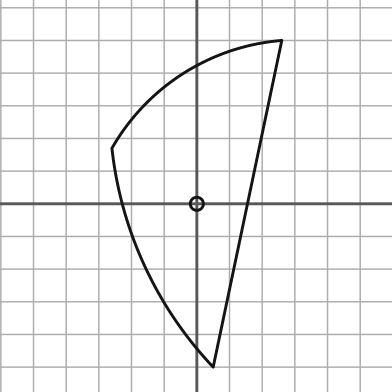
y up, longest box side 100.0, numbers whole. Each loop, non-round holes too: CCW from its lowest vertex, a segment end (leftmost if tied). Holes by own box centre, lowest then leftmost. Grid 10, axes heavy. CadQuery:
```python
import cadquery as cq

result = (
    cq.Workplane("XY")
    .moveTo(5.0, -50.0)
    .lineTo(26.0, 50.0)
    .threePointArc((-4.0, 40.0), (-26.0, 17.0))
    .threePointArc((-16.0, -19.0), (5.0, -50.0))
    .close()
    .moveTo(0.0, 0.0)
    .circle(2.0)
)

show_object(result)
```